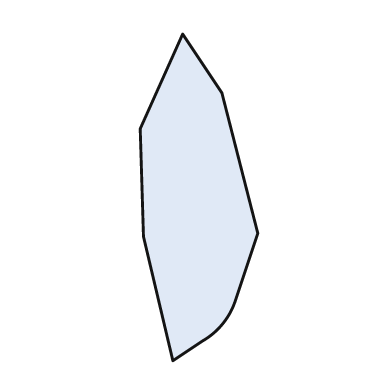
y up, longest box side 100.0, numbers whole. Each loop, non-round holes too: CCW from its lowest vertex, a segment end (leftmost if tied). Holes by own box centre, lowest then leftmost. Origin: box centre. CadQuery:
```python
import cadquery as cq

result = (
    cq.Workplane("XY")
    .moveTo(-8.0, -50.0)
    .lineTo(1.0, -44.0)
    .threePointArc((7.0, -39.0), (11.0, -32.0))
    .lineTo(18.0, -11.0)
    .lineTo(7.0, 32.0)
    .lineTo(-5.0, 50.0)
    .lineTo(-18.0, 21.0)
    .lineTo(-17.0, -12.0)
    .close()
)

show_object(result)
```